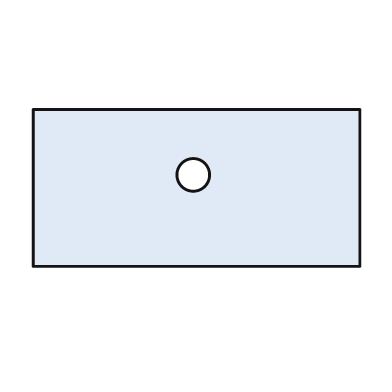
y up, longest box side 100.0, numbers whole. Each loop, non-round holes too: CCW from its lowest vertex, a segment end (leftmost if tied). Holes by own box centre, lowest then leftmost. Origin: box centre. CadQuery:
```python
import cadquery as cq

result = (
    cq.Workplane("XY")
    .moveTo(-50.0, -24.0)
    .lineTo(50.0, -24.0)
    .lineTo(50.0, 24.0)
    .lineTo(-50.0, 24.0)
    .close()
    .moveTo(-1.0, 4.0)
    .circle(5.0)
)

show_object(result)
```